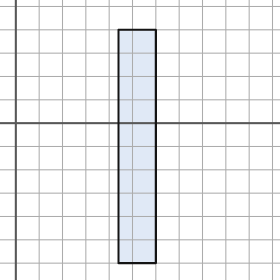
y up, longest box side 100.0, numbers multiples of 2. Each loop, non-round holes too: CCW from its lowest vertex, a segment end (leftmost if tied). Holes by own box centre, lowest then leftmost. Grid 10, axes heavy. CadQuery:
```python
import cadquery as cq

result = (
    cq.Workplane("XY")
    .moveTo(44.0, -60.0)
    .lineTo(60.0, -60.0)
    .lineTo(60.0, 40.0)
    .lineTo(44.0, 40.0)
    .close()
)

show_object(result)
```